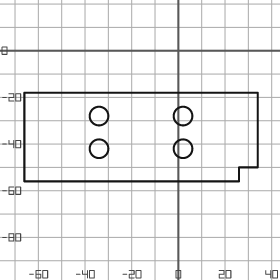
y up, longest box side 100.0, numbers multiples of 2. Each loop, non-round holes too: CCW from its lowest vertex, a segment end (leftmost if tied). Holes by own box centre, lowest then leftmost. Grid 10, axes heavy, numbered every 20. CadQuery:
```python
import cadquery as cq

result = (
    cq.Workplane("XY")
    .moveTo(-66.0, -56.0)
    .lineTo(26.0, -56.0)
    .lineTo(26.0, -50.0)
    .lineTo(34.0, -50.0)
    .lineTo(34.0, -18.0)
    .lineTo(-66.0, -18.0)
    .close()
    .moveTo(-34.0, -42.0)
    .circle(4.0)
    .moveTo(2.0, -42.0)
    .circle(4.0)
    .moveTo(-34.0, -28.0)
    .circle(4.0)
    .moveTo(2.0, -28.0)
    .circle(4.0)
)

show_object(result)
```